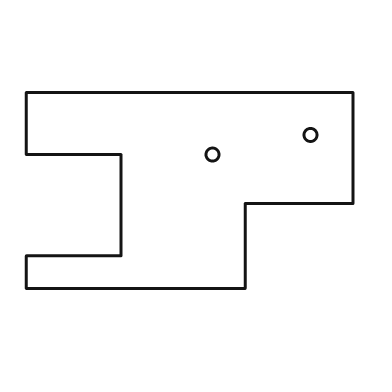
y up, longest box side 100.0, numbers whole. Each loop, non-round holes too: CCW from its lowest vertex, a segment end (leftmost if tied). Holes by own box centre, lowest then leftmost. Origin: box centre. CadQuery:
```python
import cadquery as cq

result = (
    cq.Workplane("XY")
    .moveTo(-50.0, -30.0)
    .lineTo(17.0, -30.0)
    .lineTo(17.0, -4.0)
    .lineTo(50.0, -4.0)
    .lineTo(50.0, 30.0)
    .lineTo(-50.0, 30.0)
    .lineTo(-50.0, 11.0)
    .lineTo(-21.0, 11.0)
    .lineTo(-21.0, -20.0)
    .lineTo(-50.0, -20.0)
    .close()
    .moveTo(7.0, 11.0)
    .circle(2.0)
    .moveTo(37.0, 17.0)
    .circle(2.0)
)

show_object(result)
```